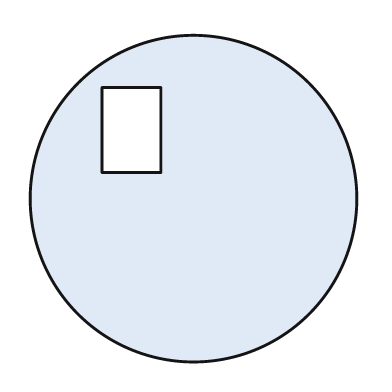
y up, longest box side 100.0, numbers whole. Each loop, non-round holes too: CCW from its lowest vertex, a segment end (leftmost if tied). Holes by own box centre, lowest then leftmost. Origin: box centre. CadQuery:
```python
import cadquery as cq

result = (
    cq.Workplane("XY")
    .moveTo(0.0, 0.0)
    .circle(50.0)
    .moveTo(-28.0, 8.0)
    .lineTo(-10.0, 8.0)
    .lineTo(-10.0, 34.0)
    .lineTo(-28.0, 34.0)
    .close()
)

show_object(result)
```